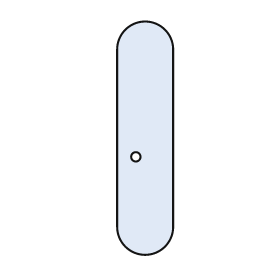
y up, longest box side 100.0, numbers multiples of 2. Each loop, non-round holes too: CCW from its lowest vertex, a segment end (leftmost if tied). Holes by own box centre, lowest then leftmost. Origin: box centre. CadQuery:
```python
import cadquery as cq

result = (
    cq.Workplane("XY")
    .moveTo(-12.0, -38.0)
    .threePointArc((0.0, -50.0), (12.0, -38.0))
    .lineTo(12.0, 38.0)
    .threePointArc((0.0, 50.0), (-12.0, 38.0))
    .close()
    .moveTo(-4.0, -8.0)
    .circle(2.0)
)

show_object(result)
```